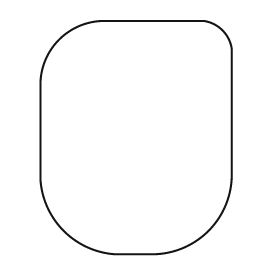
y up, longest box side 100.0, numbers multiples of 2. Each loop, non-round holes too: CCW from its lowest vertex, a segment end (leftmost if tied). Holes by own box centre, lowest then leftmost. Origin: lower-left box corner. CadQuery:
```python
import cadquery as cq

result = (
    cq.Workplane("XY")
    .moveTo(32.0, 0.0)
    .lineTo(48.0, 0.0)
    .threePointArc((72.0, 10.0), (82.0, 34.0))
    .lineTo(82.0, 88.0)
    .threePointArc((78.0, 96.0), (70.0, 100.0))
    .lineTo(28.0, 100.0)
    .threePointArc((8.0, 92.0), (0.0, 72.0))
    .lineTo(0.0, 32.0)
    .threePointArc((10.0, 10.0), (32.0, 0.0))
    .close()
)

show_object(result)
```